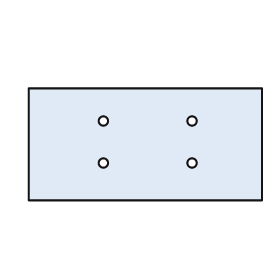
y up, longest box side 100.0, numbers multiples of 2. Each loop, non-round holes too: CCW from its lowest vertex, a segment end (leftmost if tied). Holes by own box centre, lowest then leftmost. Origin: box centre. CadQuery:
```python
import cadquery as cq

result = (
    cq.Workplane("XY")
    .moveTo(-50.0, -24.0)
    .lineTo(50.0, -24.0)
    .lineTo(50.0, 24.0)
    .lineTo(-50.0, 24.0)
    .close()
    .moveTo(-18.0, -8.0)
    .circle(2.0)
    .moveTo(20.0, -8.0)
    .circle(2.0)
    .moveTo(-18.0, 10.0)
    .circle(2.0)
    .moveTo(20.0, 10.0)
    .circle(2.0)
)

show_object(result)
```